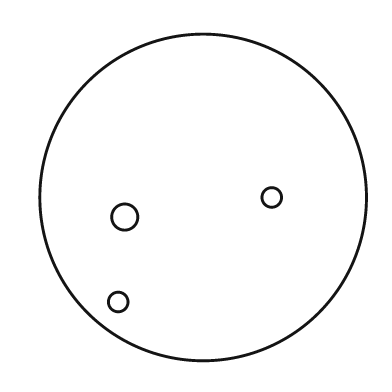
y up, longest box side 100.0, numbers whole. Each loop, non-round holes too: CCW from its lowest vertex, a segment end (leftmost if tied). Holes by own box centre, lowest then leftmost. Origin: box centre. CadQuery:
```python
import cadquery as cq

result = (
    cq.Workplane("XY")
    .moveTo(0.0, 0.0)
    .circle(50.0)
    .moveTo(-26.0, -32.0)
    .circle(3.0)
    .moveTo(-24.0, -6.0)
    .circle(4.0)
    .moveTo(21.0, 0.0)
    .circle(3.0)
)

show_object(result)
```